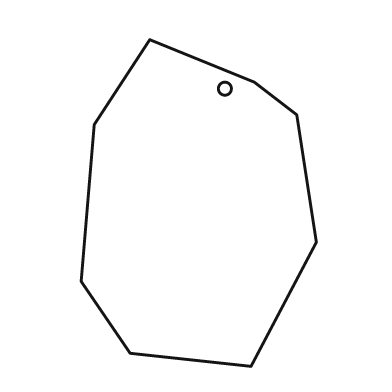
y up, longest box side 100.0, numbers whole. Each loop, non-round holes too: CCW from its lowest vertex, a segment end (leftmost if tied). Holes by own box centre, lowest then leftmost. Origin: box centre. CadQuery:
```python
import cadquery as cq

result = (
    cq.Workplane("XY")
    .moveTo(16.0, -50.0)
    .lineTo(36.0, -12.0)
    .lineTo(30.0, 27.0)
    .lineTo(17.0, 37.0)
    .lineTo(-15.0, 50.0)
    .lineTo(-32.0, 24.0)
    .lineTo(-36.0, -24.0)
    .lineTo(-21.0, -46.0)
    .close()
    .moveTo(8.0, 35.0)
    .circle(2.0)
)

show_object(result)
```